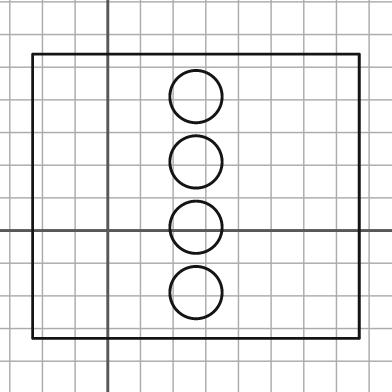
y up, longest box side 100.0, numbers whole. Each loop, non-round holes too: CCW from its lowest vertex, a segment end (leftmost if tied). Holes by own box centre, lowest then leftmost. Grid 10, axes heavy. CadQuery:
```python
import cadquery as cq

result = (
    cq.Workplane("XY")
    .moveTo(-23.0, -33.0)
    .lineTo(77.0, -33.0)
    .lineTo(77.0, 54.0)
    .lineTo(-23.0, 54.0)
    .close()
    .moveTo(27.0, -19.0)
    .circle(8.0)
    .moveTo(27.0, 1.0)
    .circle(8.0)
    .moveTo(27.0, 21.0)
    .circle(8.0)
    .moveTo(27.0, 41.0)
    .circle(8.0)
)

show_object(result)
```